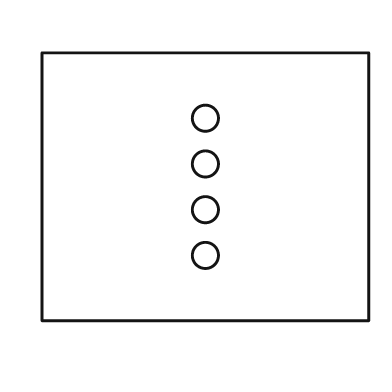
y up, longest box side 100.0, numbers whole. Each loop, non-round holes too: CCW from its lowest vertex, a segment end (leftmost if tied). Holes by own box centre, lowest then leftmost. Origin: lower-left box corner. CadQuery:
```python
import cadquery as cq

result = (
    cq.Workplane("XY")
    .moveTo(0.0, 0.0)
    .lineTo(100.0, 0.0)
    .lineTo(100.0, 82.0)
    .lineTo(0.0, 82.0)
    .close()
    .moveTo(50.0, 20.0)
    .circle(4.0)
    .moveTo(50.0, 34.0)
    .circle(4.0)
    .moveTo(50.0, 48.0)
    .circle(4.0)
    .moveTo(50.0, 62.0)
    .circle(4.0)
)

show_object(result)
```